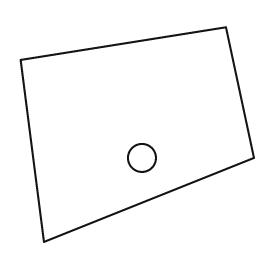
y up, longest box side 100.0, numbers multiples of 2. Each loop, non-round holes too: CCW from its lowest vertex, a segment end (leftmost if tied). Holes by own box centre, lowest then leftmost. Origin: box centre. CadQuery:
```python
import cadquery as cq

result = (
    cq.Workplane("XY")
    .moveTo(-40.0, -46.0)
    .lineTo(50.0, -10.0)
    .lineTo(38.0, 46.0)
    .lineTo(-50.0, 32.0)
    .close()
    .moveTo(2.0, -10.0)
    .circle(6.0)
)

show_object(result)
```